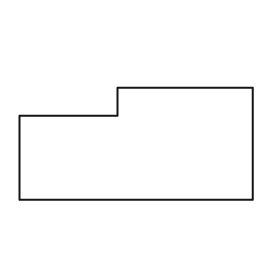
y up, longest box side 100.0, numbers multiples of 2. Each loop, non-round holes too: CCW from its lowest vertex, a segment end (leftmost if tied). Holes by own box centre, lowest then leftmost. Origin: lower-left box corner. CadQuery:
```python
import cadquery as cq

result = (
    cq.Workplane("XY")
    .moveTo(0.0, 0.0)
    .lineTo(100.0, 0.0)
    .lineTo(100.0, 48.0)
    .lineTo(42.0, 48.0)
    .lineTo(42.0, 36.0)
    .lineTo(0.0, 36.0)
    .close()
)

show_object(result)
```